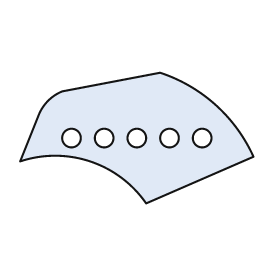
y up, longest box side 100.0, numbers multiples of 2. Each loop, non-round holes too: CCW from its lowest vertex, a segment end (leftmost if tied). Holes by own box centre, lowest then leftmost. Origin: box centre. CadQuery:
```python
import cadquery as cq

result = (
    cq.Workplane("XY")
    .moveTo(4.0, -28.0)
    .lineTo(50.0, -8.0)
    .threePointArc((34.0, 14.0), (10.0, 28.0))
    .lineTo(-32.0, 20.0)
    .threePointArc((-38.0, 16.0), (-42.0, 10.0))
    .lineTo(-50.0, -10.0)
    .threePointArc((-20.0, -10.0), (4.0, -28.0))
    .close()
    .moveTo(-28.0, 0.0)
    .circle(4.0)
    .moveTo(-14.0, 0.0)
    .circle(4.0)
    .moveTo(0.0, 0.0)
    .circle(4.0)
    .moveTo(14.0, 0.0)
    .circle(4.0)
    .moveTo(28.0, 0.0)
    .circle(4.0)
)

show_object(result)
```